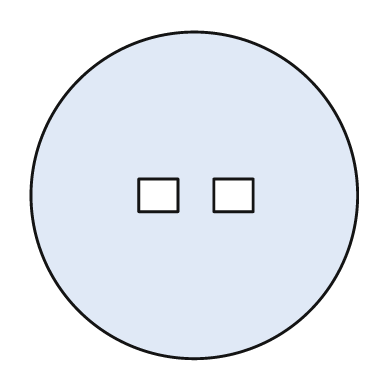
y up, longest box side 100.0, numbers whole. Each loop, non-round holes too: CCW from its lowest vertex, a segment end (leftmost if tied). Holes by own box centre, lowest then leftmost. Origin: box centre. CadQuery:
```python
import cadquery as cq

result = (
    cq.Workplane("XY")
    .moveTo(0.0, 0.0)
    .circle(50.0)
    .moveTo(-17.0, -5.0)
    .lineTo(-5.0, -5.0)
    .lineTo(-5.0, 5.0)
    .lineTo(-17.0, 5.0)
    .close()
    .moveTo(6.0, -5.0)
    .lineTo(18.0, -5.0)
    .lineTo(18.0, 5.0)
    .lineTo(6.0, 5.0)
    .close()
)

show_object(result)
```